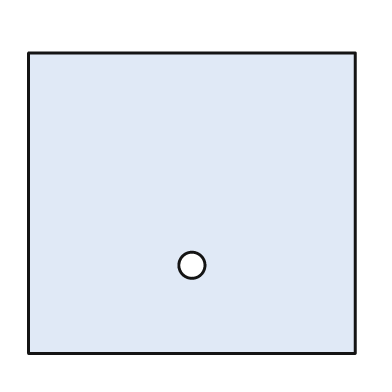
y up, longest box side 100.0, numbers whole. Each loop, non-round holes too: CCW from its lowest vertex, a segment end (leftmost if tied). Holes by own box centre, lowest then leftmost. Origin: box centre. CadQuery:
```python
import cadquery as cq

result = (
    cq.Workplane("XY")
    .moveTo(-50.0, -46.0)
    .lineTo(50.0, -46.0)
    .lineTo(50.0, 46.0)
    .lineTo(-50.0, 46.0)
    .close()
    .moveTo(0.0, -19.0)
    .circle(4.0)
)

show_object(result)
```